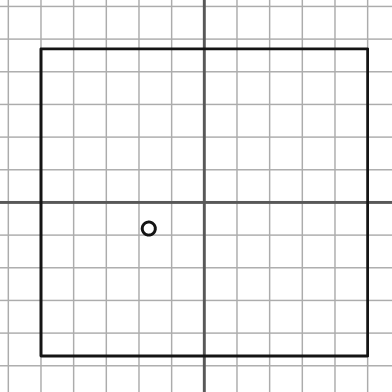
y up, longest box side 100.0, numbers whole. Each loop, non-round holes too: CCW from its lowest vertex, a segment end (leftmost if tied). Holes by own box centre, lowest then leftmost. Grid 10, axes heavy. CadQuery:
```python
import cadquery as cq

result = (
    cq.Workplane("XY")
    .moveTo(-50.0, -47.0)
    .lineTo(50.0, -47.0)
    .lineTo(50.0, 47.0)
    .lineTo(-50.0, 47.0)
    .close()
    .moveTo(-17.0, -8.0)
    .circle(2.0)
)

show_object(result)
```